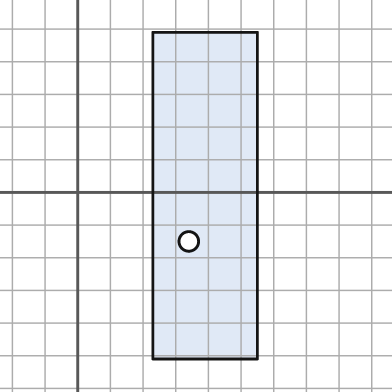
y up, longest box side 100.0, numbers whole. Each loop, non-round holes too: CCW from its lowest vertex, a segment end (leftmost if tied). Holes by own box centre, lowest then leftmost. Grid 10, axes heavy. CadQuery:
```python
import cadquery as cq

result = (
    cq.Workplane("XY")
    .moveTo(23.0, -51.0)
    .lineTo(55.0, -51.0)
    .lineTo(55.0, 49.0)
    .lineTo(23.0, 49.0)
    .close()
    .moveTo(34.0, -15.0)
    .circle(3.0)
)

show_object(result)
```